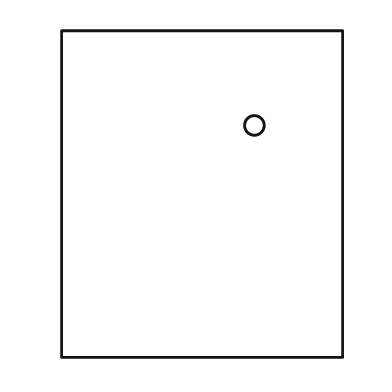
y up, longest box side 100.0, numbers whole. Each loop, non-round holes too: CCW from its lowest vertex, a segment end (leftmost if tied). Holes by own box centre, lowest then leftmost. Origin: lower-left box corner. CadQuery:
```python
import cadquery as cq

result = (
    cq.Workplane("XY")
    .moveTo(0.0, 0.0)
    .lineTo(86.0, 0.0)
    .lineTo(86.0, 100.0)
    .lineTo(0.0, 100.0)
    .close()
    .moveTo(59.0, 71.0)
    .circle(3.0)
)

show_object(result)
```